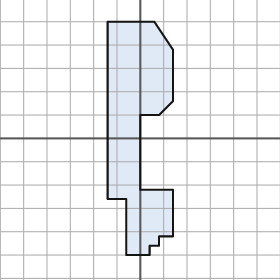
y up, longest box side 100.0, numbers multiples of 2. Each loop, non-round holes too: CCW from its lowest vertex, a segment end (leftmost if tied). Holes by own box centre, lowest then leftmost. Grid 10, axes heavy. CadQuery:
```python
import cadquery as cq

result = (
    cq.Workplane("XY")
    .moveTo(-6.0, -50.0)
    .lineTo(4.0, -50.0)
    .lineTo(4.0, -46.0)
    .lineTo(8.0, -46.0)
    .lineTo(8.0, -42.0)
    .lineTo(14.0, -42.0)
    .lineTo(14.0, -22.0)
    .lineTo(0.0, -22.0)
    .lineTo(0.0, 10.0)
    .lineTo(8.0, 10.0)
    .lineTo(14.0, 16.0)
    .lineTo(14.0, 38.0)
    .lineTo(6.0, 50.0)
    .lineTo(-14.0, 50.0)
    .lineTo(-14.0, -26.0)
    .lineTo(-6.0, -26.0)
    .close()
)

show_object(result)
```